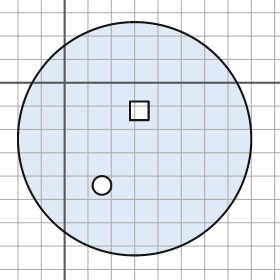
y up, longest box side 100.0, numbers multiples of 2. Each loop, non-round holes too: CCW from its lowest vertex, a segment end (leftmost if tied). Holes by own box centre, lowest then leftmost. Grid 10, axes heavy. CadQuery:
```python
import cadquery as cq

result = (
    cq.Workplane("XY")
    .moveTo(30.0, -24.0)
    .circle(50.0)
    .moveTo(16.0, -44.0)
    .circle(4.0)
    .moveTo(28.0, -16.0)
    .lineTo(36.0, -16.0)
    .lineTo(36.0, -8.0)
    .lineTo(28.0, -8.0)
    .close()
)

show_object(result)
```